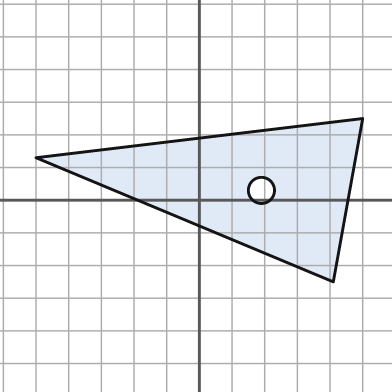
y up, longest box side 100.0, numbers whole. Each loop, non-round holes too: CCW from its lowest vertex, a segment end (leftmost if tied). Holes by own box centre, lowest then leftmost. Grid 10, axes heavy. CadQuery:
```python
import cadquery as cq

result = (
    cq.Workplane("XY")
    .moveTo(41.0, -25.0)
    .lineTo(50.0, 25.0)
    .lineTo(-50.0, 13.0)
    .close()
    .moveTo(19.0, 3.0)
    .circle(4.0)
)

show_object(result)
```